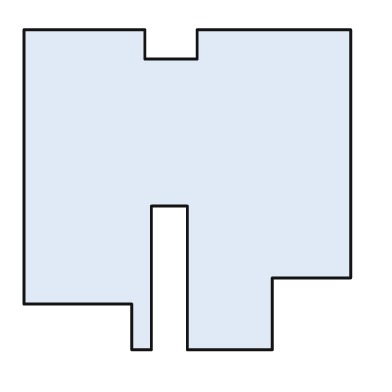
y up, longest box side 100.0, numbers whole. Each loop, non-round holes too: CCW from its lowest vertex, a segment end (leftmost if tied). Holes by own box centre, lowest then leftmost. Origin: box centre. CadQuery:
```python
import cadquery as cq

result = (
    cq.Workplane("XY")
    .moveTo(-17.0, -49.0)
    .lineTo(-11.0, -49.0)
    .lineTo(-11.0, -5.0)
    .lineTo(0.0, -5.0)
    .lineTo(0.0, -49.0)
    .lineTo(26.0, -49.0)
    .lineTo(26.0, -27.0)
    .lineTo(50.0, -27.0)
    .lineTo(50.0, 49.0)
    .lineTo(3.0, 49.0)
    .lineTo(3.0, 40.0)
    .lineTo(-13.0, 40.0)
    .lineTo(-13.0, 49.0)
    .lineTo(-50.0, 49.0)
    .lineTo(-50.0, -35.0)
    .lineTo(-17.0, -35.0)
    .close()
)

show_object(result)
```